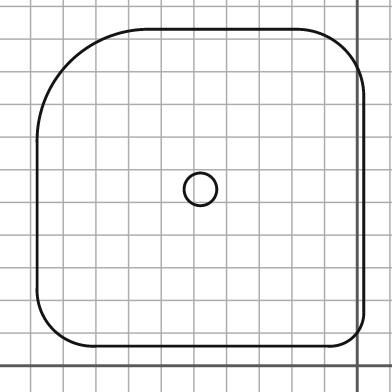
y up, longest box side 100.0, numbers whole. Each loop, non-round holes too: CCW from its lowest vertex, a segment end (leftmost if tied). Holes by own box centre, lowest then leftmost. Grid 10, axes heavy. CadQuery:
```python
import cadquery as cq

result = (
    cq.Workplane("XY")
    .moveTo(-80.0, 6.0)
    .lineTo(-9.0, 6.0)
    .threePointArc((-1.0, 9.0), (2.0, 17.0))
    .lineTo(2.0, 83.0)
    .threePointArc((-4.0, 97.0), (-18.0, 103.0))
    .lineTo(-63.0, 103.0)
    .threePointArc((-88.0, 93.0), (-98.0, 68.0))
    .lineTo(-98.0, 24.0)
    .threePointArc((-93.0, 11.0), (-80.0, 6.0))
    .close()
    .moveTo(-48.0, 54.0)
    .circle(5.0)
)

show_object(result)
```